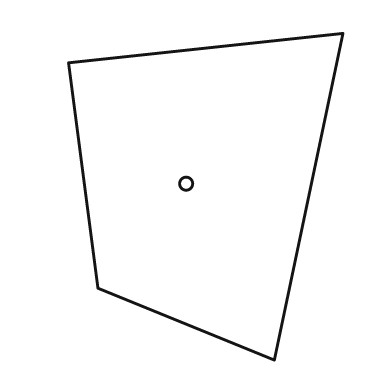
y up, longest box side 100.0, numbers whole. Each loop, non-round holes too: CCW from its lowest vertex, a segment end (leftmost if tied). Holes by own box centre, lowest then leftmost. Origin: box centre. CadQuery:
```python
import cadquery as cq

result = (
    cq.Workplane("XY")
    .moveTo(21.0, -50.0)
    .lineTo(42.0, 50.0)
    .lineTo(-42.0, 41.0)
    .lineTo(-33.0, -28.0)
    .close()
    .moveTo(-6.0, 4.0)
    .circle(2.0)
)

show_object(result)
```